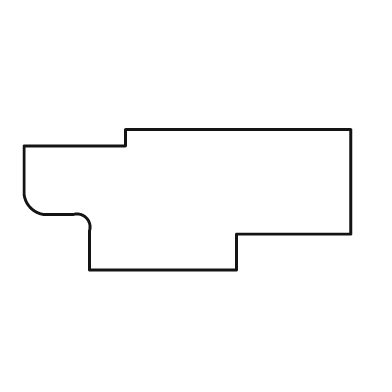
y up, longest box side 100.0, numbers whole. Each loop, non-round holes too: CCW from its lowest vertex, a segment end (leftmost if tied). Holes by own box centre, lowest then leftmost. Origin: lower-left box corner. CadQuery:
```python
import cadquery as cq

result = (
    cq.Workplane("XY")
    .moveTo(20.0, 0.0)
    .lineTo(65.0, 0.0)
    .lineTo(65.0, 11.0)
    .lineTo(100.0, 11.0)
    .lineTo(100.0, 43.0)
    .lineTo(31.0, 43.0)
    .lineTo(31.0, 38.0)
    .lineTo(0.0, 38.0)
    .lineTo(0.0, 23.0)
    .threePointArc((2.0, 19.0), (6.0, 17.0))
    .lineTo(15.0, 17.0)
    .threePointArc((19.0, 16.0), (20.0, 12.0))
    .close()
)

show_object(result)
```